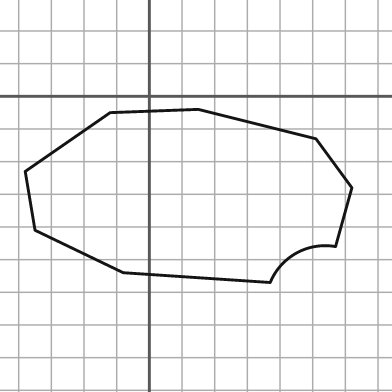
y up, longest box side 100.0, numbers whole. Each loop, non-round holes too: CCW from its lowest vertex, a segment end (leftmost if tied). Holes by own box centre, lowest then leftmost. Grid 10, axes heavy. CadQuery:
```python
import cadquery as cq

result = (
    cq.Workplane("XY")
    .moveTo(37.0, -57.0)
    .threePointArc((45.0, -48.0), (57.0, -46.0))
    .lineTo(62.0, -28.0)
    .lineTo(51.0, -13.0)
    .lineTo(15.0, -4.0)
    .lineTo(-12.0, -5.0)
    .lineTo(-38.0, -23.0)
    .lineTo(-35.0, -41.0)
    .lineTo(-8.0, -54.0)
    .close()
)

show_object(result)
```